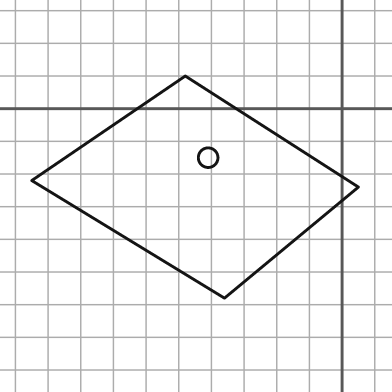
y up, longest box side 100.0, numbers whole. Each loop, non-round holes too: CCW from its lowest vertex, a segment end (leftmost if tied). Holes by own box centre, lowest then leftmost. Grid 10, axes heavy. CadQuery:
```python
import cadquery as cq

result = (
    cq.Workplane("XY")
    .moveTo(-36.0, -58.0)
    .lineTo(5.0, -24.0)
    .lineTo(-48.0, 10.0)
    .lineTo(-95.0, -22.0)
    .close()
    .moveTo(-41.0, -15.0)
    .circle(3.0)
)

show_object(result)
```